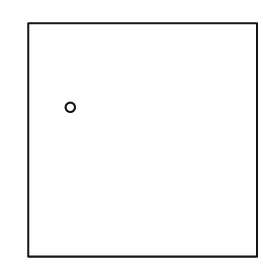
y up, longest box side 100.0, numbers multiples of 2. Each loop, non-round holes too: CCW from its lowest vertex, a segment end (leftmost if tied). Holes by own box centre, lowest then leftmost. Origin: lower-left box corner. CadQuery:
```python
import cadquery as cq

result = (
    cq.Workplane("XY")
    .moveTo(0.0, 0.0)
    .lineTo(98.0, 0.0)
    .lineTo(98.0, 100.0)
    .lineTo(0.0, 100.0)
    .close()
    .moveTo(18.0, 64.0)
    .circle(2.0)
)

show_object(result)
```